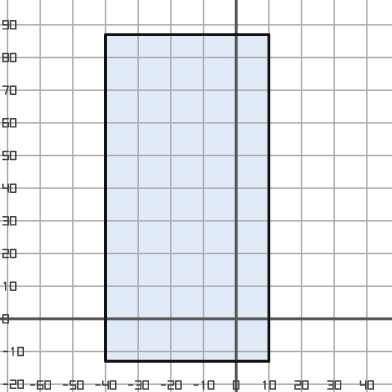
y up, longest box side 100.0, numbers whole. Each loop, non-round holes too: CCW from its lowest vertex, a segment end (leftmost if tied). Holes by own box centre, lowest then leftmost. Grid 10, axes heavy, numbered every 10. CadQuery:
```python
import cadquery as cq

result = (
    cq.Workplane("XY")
    .moveTo(-40.0, -13.0)
    .lineTo(10.0, -13.0)
    .lineTo(10.0, 87.0)
    .lineTo(-40.0, 87.0)
    .close()
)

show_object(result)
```